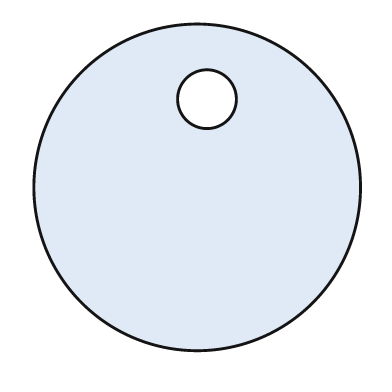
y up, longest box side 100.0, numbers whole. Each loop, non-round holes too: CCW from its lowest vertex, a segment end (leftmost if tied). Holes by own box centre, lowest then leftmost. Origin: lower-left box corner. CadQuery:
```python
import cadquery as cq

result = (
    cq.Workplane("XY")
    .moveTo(50.0, 50.0)
    .circle(50.0)
    .moveTo(53.0, 77.0)
    .circle(9.0)
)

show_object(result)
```